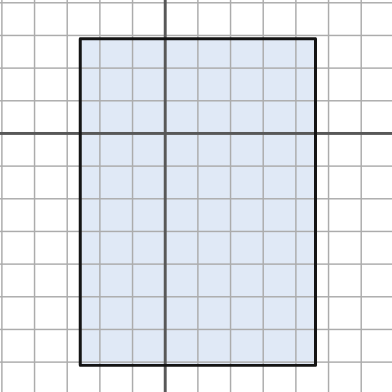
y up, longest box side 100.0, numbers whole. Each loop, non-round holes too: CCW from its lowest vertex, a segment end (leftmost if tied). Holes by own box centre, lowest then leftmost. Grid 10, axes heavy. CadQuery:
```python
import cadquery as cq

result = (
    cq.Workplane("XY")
    .moveTo(-26.0, -71.0)
    .lineTo(46.0, -71.0)
    .lineTo(46.0, 29.0)
    .lineTo(-26.0, 29.0)
    .close()
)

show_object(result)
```